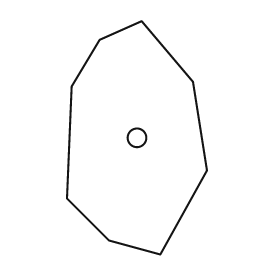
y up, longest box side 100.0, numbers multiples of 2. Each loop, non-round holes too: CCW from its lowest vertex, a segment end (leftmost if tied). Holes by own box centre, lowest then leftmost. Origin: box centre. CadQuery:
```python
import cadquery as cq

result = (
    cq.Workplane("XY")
    .moveTo(10.0, -50.0)
    .lineTo(30.0, -14.0)
    .lineTo(24.0, 24.0)
    .lineTo(2.0, 50.0)
    .lineTo(-16.0, 42.0)
    .lineTo(-28.0, 22.0)
    .lineTo(-30.0, -26.0)
    .lineTo(-12.0, -44.0)
    .close()
    .moveTo(0.0, 0.0)
    .circle(4.0)
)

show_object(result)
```